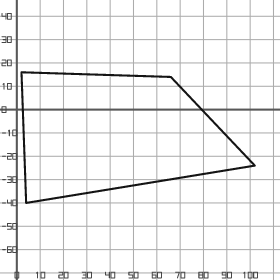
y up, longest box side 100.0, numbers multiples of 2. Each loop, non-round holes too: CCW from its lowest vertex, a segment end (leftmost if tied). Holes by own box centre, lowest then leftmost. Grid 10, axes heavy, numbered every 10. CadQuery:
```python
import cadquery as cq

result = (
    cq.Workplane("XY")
    .moveTo(4.0, -40.0)
    .lineTo(102.0, -24.0)
    .lineTo(66.0, 14.0)
    .lineTo(2.0, 16.0)
    .close()
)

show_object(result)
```